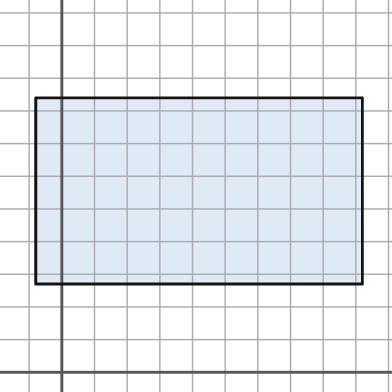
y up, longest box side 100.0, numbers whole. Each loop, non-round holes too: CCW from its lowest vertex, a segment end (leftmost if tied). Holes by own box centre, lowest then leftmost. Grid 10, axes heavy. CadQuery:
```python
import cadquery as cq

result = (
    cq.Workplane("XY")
    .moveTo(-8.0, 27.0)
    .lineTo(92.0, 27.0)
    .lineTo(92.0, 84.0)
    .lineTo(-8.0, 84.0)
    .close()
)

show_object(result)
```